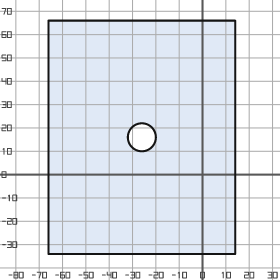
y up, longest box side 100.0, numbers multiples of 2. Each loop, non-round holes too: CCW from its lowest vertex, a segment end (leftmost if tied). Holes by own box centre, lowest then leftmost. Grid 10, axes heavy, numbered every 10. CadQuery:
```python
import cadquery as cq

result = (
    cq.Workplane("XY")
    .moveTo(-66.0, -34.0)
    .lineTo(14.0, -34.0)
    .lineTo(14.0, 66.0)
    .lineTo(-66.0, 66.0)
    .close()
    .moveTo(-26.0, 16.0)
    .circle(6.0)
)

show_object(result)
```